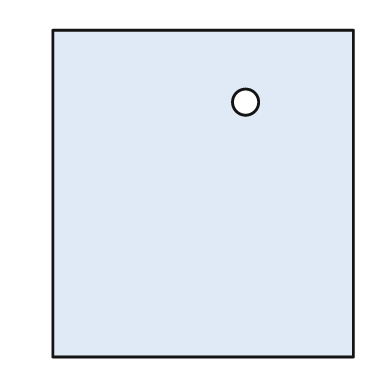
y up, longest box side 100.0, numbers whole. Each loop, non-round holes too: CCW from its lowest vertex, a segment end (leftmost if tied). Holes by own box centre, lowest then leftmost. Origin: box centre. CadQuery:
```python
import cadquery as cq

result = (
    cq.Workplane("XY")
    .moveTo(-46.0, -50.0)
    .lineTo(46.0, -50.0)
    .lineTo(46.0, 50.0)
    .lineTo(-46.0, 50.0)
    .close()
    .moveTo(13.0, 28.0)
    .circle(4.0)
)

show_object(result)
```